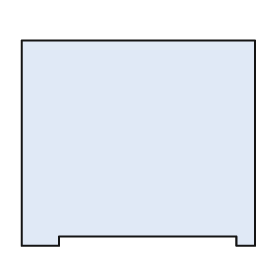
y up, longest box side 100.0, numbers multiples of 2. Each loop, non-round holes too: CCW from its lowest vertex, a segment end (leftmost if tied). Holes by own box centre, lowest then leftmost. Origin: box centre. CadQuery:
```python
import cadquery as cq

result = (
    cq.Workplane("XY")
    .moveTo(-50.0, -44.0)
    .lineTo(-34.0, -44.0)
    .lineTo(-34.0, -40.0)
    .lineTo(42.0, -40.0)
    .lineTo(42.0, -44.0)
    .lineTo(50.0, -44.0)
    .lineTo(50.0, 44.0)
    .lineTo(-50.0, 44.0)
    .close()
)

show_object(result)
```